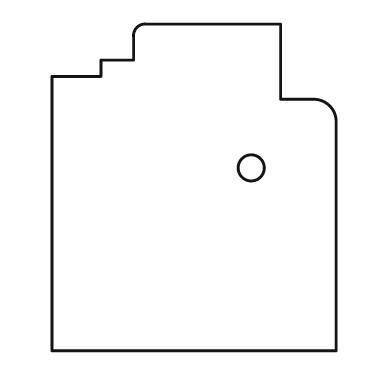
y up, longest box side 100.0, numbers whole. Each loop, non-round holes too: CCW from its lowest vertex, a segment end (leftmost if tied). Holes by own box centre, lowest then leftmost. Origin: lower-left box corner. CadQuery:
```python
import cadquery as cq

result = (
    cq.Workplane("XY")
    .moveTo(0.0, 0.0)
    .lineTo(87.0, 0.0)
    .lineTo(87.0, 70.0)
    .threePointArc((85.0, 75.0), (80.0, 77.0))
    .lineTo(70.0, 77.0)
    .lineTo(70.0, 100.0)
    .lineTo(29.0, 100.0)
    .threePointArc((26.0, 99.0), (25.0, 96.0))
    .lineTo(25.0, 89.0)
    .lineTo(15.0, 89.0)
    .lineTo(15.0, 84.0)
    .lineTo(0.0, 84.0)
    .close()
    .moveTo(61.0, 56.0)
    .circle(4.0)
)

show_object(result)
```